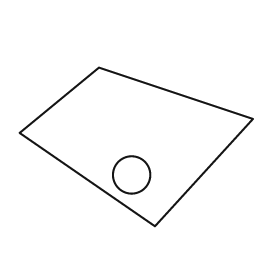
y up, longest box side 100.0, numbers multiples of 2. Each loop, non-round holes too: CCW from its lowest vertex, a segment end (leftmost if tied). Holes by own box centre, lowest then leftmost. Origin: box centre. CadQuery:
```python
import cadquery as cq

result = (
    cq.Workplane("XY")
    .moveTo(8.0, -34.0)
    .lineTo(50.0, 12.0)
    .lineTo(-16.0, 34.0)
    .lineTo(-50.0, 6.0)
    .close()
    .moveTo(-2.0, -12.0)
    .circle(8.0)
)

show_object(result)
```